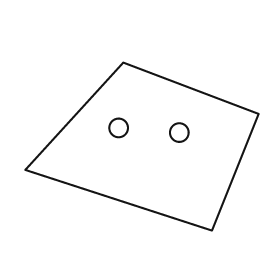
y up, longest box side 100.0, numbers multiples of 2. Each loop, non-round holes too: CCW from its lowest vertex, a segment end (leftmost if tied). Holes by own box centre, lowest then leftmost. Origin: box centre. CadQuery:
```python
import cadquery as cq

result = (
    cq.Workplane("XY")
    .moveTo(30.0, -36.0)
    .lineTo(50.0, 14.0)
    .lineTo(-8.0, 36.0)
    .lineTo(-50.0, -10.0)
    .close()
    .moveTo(16.0, 6.0)
    .circle(4.0)
    .moveTo(-10.0, 8.0)
    .circle(4.0)
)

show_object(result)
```